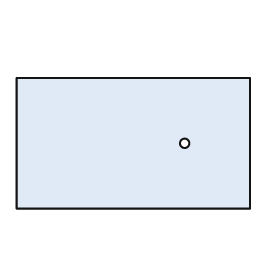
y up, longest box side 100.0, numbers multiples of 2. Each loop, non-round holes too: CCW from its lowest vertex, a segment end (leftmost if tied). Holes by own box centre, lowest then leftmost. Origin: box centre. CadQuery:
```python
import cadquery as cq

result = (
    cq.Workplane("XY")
    .moveTo(-50.0, -28.0)
    .lineTo(50.0, -28.0)
    .lineTo(50.0, 28.0)
    .lineTo(-50.0, 28.0)
    .close()
    .moveTo(22.0, 0.0)
    .circle(2.0)
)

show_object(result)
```